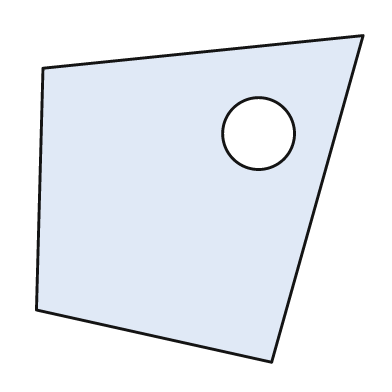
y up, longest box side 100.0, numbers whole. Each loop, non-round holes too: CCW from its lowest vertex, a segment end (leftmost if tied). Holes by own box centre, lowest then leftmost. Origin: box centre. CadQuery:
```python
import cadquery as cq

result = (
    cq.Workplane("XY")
    .moveTo(22.0, -50.0)
    .lineTo(50.0, 50.0)
    .lineTo(-48.0, 40.0)
    .lineTo(-50.0, -34.0)
    .close()
    .moveTo(18.0, 20.0)
    .circle(11.0)
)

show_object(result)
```